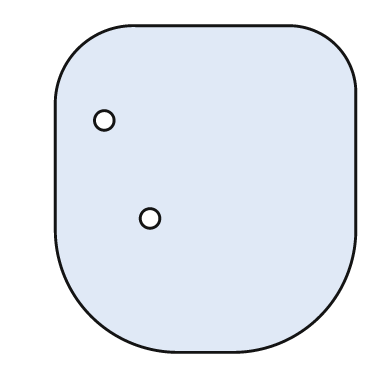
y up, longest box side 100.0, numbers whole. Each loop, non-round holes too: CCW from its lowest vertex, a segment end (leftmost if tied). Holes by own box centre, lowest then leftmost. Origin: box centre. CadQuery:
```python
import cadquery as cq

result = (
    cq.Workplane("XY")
    .moveTo(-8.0, -50.0)
    .lineTo(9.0, -50.0)
    .threePointArc((35.0, -39.0), (46.0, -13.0))
    .lineTo(46.0, 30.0)
    .threePointArc((40.0, 44.0), (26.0, 50.0))
    .lineTo(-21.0, 50.0)
    .threePointArc((-39.0, 43.0), (-46.0, 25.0))
    .lineTo(-46.0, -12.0)
    .threePointArc((-35.0, -39.0), (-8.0, -50.0))
    .close()
    .moveTo(-17.0, -9.0)
    .circle(3.0)
    .moveTo(-31.0, 21.0)
    .circle(3.0)
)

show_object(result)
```